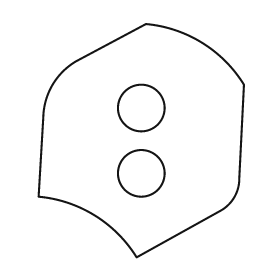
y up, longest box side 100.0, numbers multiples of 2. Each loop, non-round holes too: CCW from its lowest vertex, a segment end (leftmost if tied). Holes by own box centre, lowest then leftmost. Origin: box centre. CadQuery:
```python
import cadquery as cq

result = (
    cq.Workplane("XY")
    .moveTo(-2.0, -50.0)
    .lineTo(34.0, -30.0)
    .threePointArc((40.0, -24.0), (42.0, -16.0))
    .lineTo(44.0, 24.0)
    .threePointArc((26.0, 42.0), (2.0, 50.0))
    .lineTo(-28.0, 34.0)
    .threePointArc((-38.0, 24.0), (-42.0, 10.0))
    .lineTo(-44.0, -24.0)
    .threePointArc((-20.0, -32.0), (-2.0, -50.0))
    .close()
    .moveTo(0.0, -14.0)
    .circle(10.0)
    .moveTo(0.0, 14.0)
    .circle(10.0)
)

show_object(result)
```